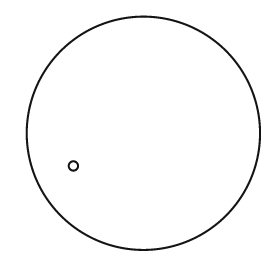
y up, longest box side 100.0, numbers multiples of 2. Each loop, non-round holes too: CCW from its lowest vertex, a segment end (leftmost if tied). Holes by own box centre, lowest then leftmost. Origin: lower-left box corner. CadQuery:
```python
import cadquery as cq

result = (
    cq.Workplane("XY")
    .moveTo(50.0, 50.0)
    .circle(50.0)
    .moveTo(20.0, 36.0)
    .circle(2.0)
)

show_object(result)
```